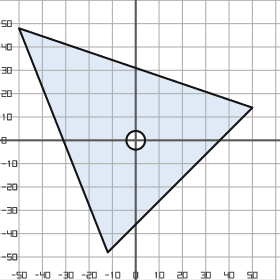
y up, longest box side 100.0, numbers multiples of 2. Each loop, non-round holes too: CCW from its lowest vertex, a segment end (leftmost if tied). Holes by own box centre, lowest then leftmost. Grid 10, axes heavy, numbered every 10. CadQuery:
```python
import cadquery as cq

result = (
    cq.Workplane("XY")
    .moveTo(-12.0, -48.0)
    .lineTo(50.0, 14.0)
    .lineTo(-50.0, 48.0)
    .close()
    .moveTo(0.0, 0.0)
    .circle(4.0)
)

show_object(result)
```